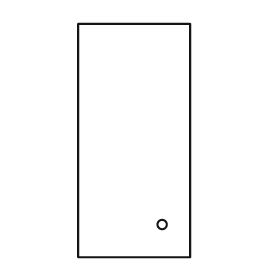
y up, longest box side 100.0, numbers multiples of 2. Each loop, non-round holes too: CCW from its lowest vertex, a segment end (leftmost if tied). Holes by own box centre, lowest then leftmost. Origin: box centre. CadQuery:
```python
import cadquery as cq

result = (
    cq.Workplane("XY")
    .moveTo(-24.0, -50.0)
    .lineTo(24.0, -50.0)
    .lineTo(24.0, 50.0)
    .lineTo(-24.0, 50.0)
    .close()
    .moveTo(12.0, -36.0)
    .circle(2.0)
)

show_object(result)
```